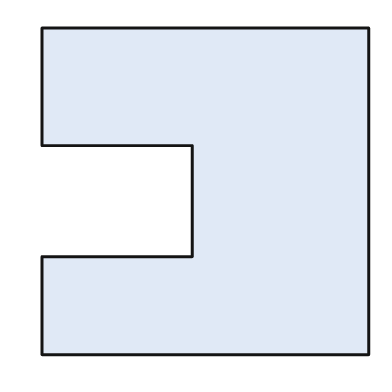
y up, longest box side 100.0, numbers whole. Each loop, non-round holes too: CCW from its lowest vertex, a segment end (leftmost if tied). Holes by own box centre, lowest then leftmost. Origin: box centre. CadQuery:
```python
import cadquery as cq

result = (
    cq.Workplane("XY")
    .moveTo(-50.0, -50.0)
    .lineTo(50.0, -50.0)
    .lineTo(50.0, 50.0)
    .lineTo(-50.0, 50.0)
    .lineTo(-50.0, 14.0)
    .lineTo(-4.0, 14.0)
    .lineTo(-4.0, -20.0)
    .lineTo(-50.0, -20.0)
    .close()
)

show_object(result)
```